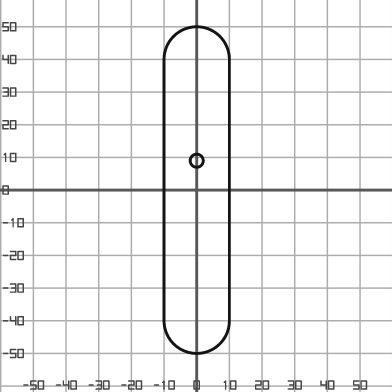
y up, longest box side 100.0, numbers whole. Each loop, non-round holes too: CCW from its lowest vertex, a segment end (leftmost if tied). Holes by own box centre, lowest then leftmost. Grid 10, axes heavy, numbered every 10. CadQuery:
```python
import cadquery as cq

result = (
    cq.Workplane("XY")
    .moveTo(-10.0, -40.0)
    .threePointArc((0.0, -50.0), (10.0, -40.0))
    .lineTo(10.0, 40.0)
    .threePointArc((0.0, 50.0), (-10.0, 40.0))
    .close()
    .moveTo(0.0, 9.0)
    .circle(2.0)
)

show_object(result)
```